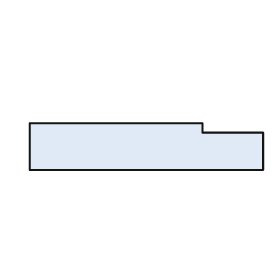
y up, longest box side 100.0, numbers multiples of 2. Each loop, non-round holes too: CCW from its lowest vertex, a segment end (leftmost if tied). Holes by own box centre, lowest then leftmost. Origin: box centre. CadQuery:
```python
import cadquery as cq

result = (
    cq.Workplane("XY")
    .moveTo(-50.0, -10.0)
    .lineTo(50.0, -10.0)
    .lineTo(50.0, 6.0)
    .lineTo(24.0, 6.0)
    .lineTo(24.0, 10.0)
    .lineTo(-50.0, 10.0)
    .close()
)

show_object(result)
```